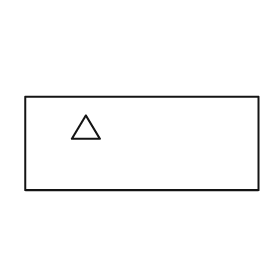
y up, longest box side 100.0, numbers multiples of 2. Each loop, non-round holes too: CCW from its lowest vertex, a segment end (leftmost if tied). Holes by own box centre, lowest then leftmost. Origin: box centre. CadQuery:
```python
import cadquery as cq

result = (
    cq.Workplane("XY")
    .moveTo(-50.0, -20.0)
    .lineTo(50.0, -20.0)
    .lineTo(50.0, 20.0)
    .lineTo(-50.0, 20.0)
    .close()
    .moveTo(-30.0, 2.0)
    .lineTo(-18.0, 2.0)
    .lineTo(-24.0, 12.0)
    .close()
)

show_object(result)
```